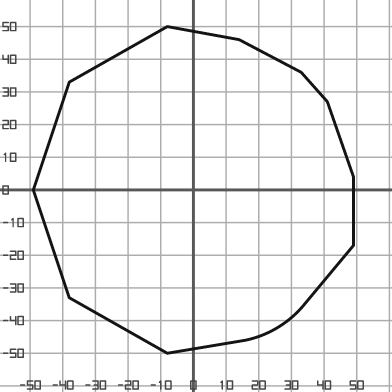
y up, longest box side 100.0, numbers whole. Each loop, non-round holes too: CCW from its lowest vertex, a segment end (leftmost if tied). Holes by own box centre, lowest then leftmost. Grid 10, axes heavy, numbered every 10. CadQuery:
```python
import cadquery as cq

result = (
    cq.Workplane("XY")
    .moveTo(-8.0, -50.0)
    .lineTo(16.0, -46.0)
    .threePointArc((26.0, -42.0), (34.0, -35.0))
    .lineTo(49.0, -17.0)
    .lineTo(49.0, 4.0)
    .lineTo(41.0, 27.0)
    .lineTo(33.0, 36.0)
    .lineTo(14.0, 46.0)
    .lineTo(-8.0, 50.0)
    .lineTo(-38.0, 33.0)
    .lineTo(-49.0, 0.0)
    .lineTo(-38.0, -33.0)
    .close()
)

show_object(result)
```